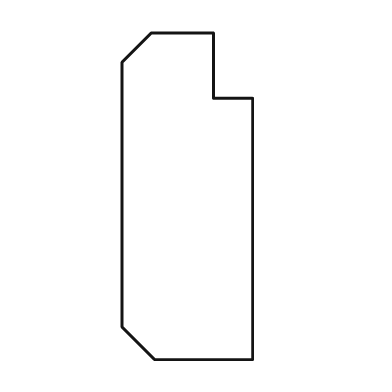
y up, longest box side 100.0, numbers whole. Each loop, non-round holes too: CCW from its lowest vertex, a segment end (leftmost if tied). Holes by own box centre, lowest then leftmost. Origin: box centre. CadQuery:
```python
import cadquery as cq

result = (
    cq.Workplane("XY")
    .moveTo(-10.0, -50.0)
    .lineTo(20.0, -50.0)
    .lineTo(20.0, 30.0)
    .lineTo(8.0, 30.0)
    .lineTo(8.0, 50.0)
    .lineTo(-11.0, 50.0)
    .lineTo(-20.0, 41.0)
    .lineTo(-20.0, -40.0)
    .close()
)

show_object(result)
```